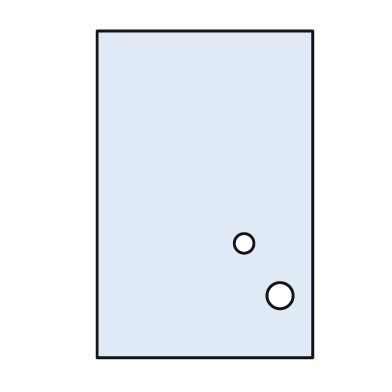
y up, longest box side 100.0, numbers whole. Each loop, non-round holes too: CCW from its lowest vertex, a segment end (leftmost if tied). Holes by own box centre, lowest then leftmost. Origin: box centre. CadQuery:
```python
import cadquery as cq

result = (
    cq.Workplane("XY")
    .moveTo(-33.0, -50.0)
    .lineTo(33.0, -50.0)
    .lineTo(33.0, 50.0)
    .lineTo(-33.0, 50.0)
    .close()
    .moveTo(23.0, -31.0)
    .circle(4.0)
    .moveTo(12.0, -15.0)
    .circle(3.0)
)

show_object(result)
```